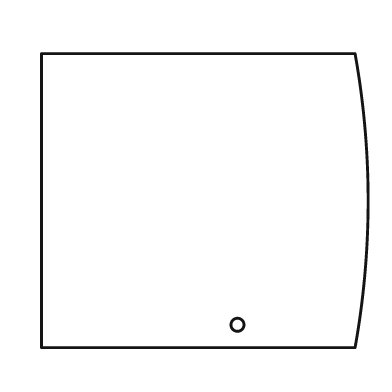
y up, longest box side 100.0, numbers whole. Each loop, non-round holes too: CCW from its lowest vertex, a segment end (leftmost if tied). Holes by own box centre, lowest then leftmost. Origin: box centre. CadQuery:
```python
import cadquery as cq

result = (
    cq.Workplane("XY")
    .moveTo(-50.0, -45.0)
    .lineTo(46.0, -45.0)
    .threePointArc((50.0, 0.0), (46.0, 45.0))
    .lineTo(-50.0, 45.0)
    .close()
    .moveTo(10.0, -38.0)
    .circle(2.0)
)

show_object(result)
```